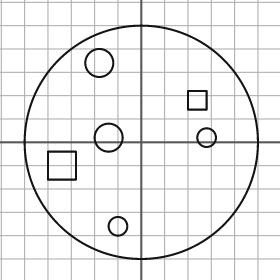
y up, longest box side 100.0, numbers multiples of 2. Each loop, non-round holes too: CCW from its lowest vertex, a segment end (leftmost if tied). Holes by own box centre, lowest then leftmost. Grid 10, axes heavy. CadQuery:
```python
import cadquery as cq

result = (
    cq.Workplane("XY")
    .moveTo(0.0, 0.0)
    .circle(50.0)
    .moveTo(-10.0, -36.0)
    .circle(4.0)
    .moveTo(-40.0, -16.0)
    .lineTo(-28.0, -16.0)
    .lineTo(-28.0, -4.0)
    .lineTo(-40.0, -4.0)
    .close()
    .moveTo(-14.0, 2.0)
    .circle(6.0)
    .moveTo(28.0, 2.0)
    .circle(4.0)
    .moveTo(20.0, 14.0)
    .lineTo(28.0, 14.0)
    .lineTo(28.0, 22.0)
    .lineTo(20.0, 22.0)
    .close()
    .moveTo(-18.0, 34.0)
    .circle(6.0)
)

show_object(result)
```